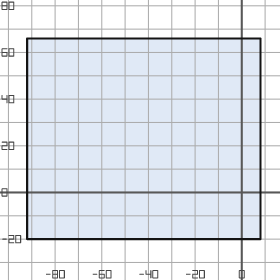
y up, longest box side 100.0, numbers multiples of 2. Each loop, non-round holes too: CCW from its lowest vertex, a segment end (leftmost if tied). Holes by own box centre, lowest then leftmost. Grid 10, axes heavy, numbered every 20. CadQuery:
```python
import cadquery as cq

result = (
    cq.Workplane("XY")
    .moveTo(-92.0, -20.0)
    .lineTo(8.0, -20.0)
    .lineTo(8.0, 66.0)
    .lineTo(-92.0, 66.0)
    .close()
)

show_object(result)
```